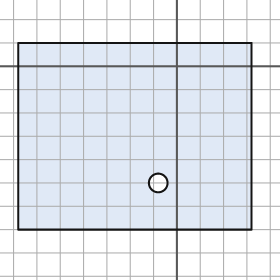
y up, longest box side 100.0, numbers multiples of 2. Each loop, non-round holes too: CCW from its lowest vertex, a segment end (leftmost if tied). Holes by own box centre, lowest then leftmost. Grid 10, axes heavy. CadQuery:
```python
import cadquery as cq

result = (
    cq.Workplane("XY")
    .moveTo(-68.0, -70.0)
    .lineTo(32.0, -70.0)
    .lineTo(32.0, 10.0)
    .lineTo(-68.0, 10.0)
    .close()
    .moveTo(-8.0, -50.0)
    .circle(4.0)
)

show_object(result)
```